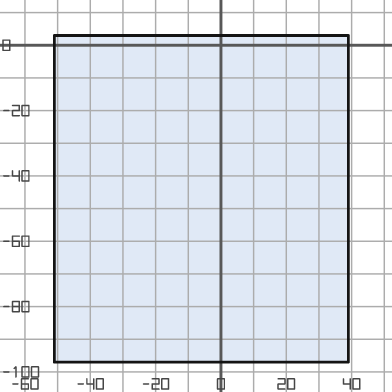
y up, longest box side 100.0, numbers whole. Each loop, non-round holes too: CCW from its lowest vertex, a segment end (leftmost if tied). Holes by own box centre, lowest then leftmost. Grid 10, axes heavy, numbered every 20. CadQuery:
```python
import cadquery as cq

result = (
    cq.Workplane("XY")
    .moveTo(-51.0, -97.0)
    .lineTo(39.0, -97.0)
    .lineTo(39.0, 3.0)
    .lineTo(-51.0, 3.0)
    .close()
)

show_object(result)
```